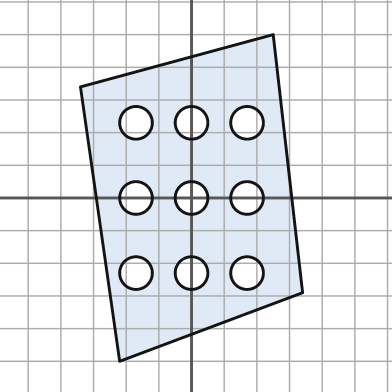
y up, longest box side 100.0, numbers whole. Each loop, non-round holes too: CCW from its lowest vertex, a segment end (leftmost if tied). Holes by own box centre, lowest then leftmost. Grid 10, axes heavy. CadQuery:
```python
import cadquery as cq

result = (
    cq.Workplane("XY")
    .moveTo(-22.0, -50.0)
    .lineTo(34.0, -29.0)
    .lineTo(25.0, 50.0)
    .lineTo(-34.0, 34.0)
    .close()
    .moveTo(-17.0, -23.0)
    .circle(5.0)
    .moveTo(0.0, -23.0)
    .circle(5.0)
    .moveTo(17.0, -23.0)
    .circle(5.0)
    .moveTo(-17.0, 0.0)
    .circle(5.0)
    .moveTo(0.0, 0.0)
    .circle(5.0)
    .moveTo(17.0, 0.0)
    .circle(5.0)
    .moveTo(-17.0, 23.0)
    .circle(5.0)
    .moveTo(0.0, 23.0)
    .circle(5.0)
    .moveTo(17.0, 23.0)
    .circle(5.0)
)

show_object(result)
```